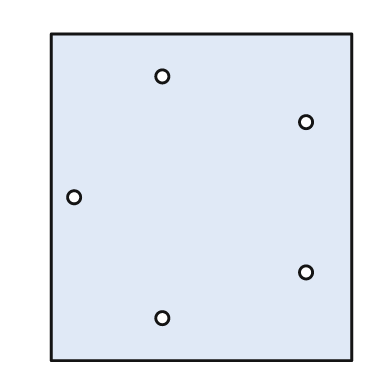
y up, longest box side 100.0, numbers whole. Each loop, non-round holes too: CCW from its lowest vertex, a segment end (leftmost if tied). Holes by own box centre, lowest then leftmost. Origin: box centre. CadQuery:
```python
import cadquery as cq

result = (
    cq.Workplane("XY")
    .moveTo(-46.0, -50.0)
    .lineTo(46.0, -50.0)
    .lineTo(46.0, 50.0)
    .lineTo(-46.0, 50.0)
    .close()
    .moveTo(-12.0, -37.0)
    .circle(2.0)
    .moveTo(32.0, -23.0)
    .circle(2.0)
    .moveTo(-39.0, 0.0)
    .circle(2.0)
    .moveTo(32.0, 23.0)
    .circle(2.0)
    .moveTo(-12.0, 37.0)
    .circle(2.0)
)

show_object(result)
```